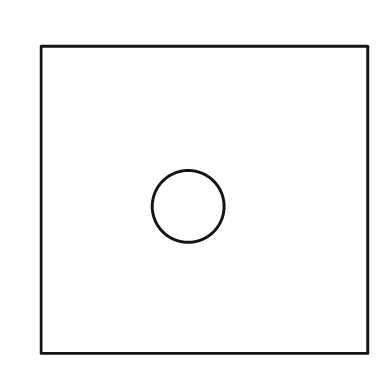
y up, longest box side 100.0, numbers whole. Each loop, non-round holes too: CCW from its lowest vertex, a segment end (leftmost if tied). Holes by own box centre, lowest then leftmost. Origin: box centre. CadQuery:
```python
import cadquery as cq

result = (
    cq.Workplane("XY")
    .moveTo(-50.0, -47.0)
    .lineTo(50.0, -47.0)
    .lineTo(50.0, 47.0)
    .lineTo(-50.0, 47.0)
    .close()
    .moveTo(-5.0, -2.0)
    .circle(11.0)
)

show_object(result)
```